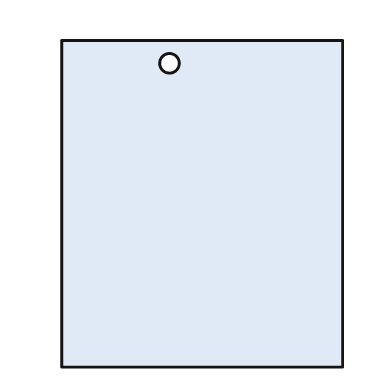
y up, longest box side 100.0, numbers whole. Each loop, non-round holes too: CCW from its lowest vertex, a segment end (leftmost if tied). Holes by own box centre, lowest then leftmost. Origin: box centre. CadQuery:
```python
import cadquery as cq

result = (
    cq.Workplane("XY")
    .moveTo(-43.0, -50.0)
    .lineTo(43.0, -50.0)
    .lineTo(43.0, 50.0)
    .lineTo(-43.0, 50.0)
    .close()
    .moveTo(-10.0, 43.0)
    .circle(3.0)
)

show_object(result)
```